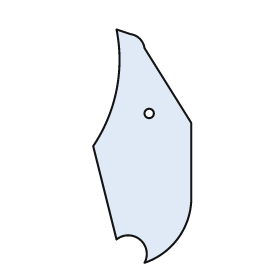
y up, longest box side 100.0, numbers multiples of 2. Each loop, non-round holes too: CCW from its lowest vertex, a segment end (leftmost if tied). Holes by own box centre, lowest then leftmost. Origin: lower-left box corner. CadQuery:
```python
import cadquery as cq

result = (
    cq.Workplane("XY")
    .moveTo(22.0, 0.0)
    .threePointArc((36.0, 10.0), (42.0, 26.0))
    .lineTo(42.0, 60.0)
    .lineTo(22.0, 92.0)
    .threePointArc((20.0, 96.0), (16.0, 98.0))
    .lineTo(10.0, 100.0)
    .threePointArc((10.0, 74.0), (0.0, 50.0))
    .lineTo(10.0, 10.0)
    .threePointArc((20.0, 10.0), (22.0, 0.0))
    .close()
    .moveTo(24.0, 64.0)
    .circle(2.0)
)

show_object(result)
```